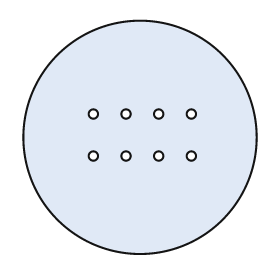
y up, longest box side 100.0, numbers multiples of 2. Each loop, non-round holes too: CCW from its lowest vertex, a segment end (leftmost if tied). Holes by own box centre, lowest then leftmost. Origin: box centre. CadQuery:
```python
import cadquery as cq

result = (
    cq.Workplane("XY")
    .moveTo(0.0, 0.0)
    .circle(50.0)
    .moveTo(-20.0, -8.0)
    .circle(2.0)
    .moveTo(-6.0, -8.0)
    .circle(2.0)
    .moveTo(8.0, -8.0)
    .circle(2.0)
    .moveTo(22.0, -8.0)
    .circle(2.0)
    .moveTo(-20.0, 10.0)
    .circle(2.0)
    .moveTo(-6.0, 10.0)
    .circle(2.0)
    .moveTo(8.0, 10.0)
    .circle(2.0)
    .moveTo(22.0, 10.0)
    .circle(2.0)
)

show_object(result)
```